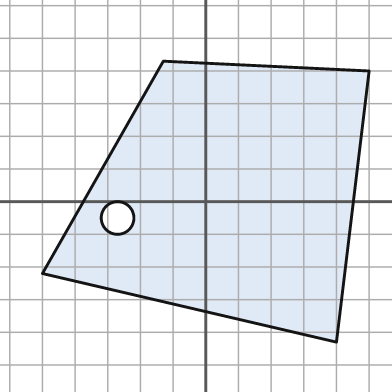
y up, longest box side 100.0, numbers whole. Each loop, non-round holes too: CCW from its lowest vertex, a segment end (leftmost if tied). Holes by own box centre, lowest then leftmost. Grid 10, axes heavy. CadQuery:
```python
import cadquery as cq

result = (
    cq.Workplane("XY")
    .moveTo(40.0, -43.0)
    .lineTo(50.0, 40.0)
    .lineTo(-13.0, 43.0)
    .lineTo(-50.0, -22.0)
    .close()
    .moveTo(-27.0, -5.0)
    .circle(5.0)
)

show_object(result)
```